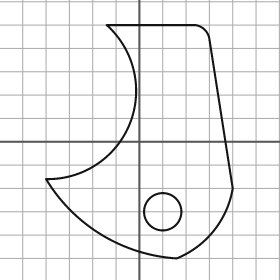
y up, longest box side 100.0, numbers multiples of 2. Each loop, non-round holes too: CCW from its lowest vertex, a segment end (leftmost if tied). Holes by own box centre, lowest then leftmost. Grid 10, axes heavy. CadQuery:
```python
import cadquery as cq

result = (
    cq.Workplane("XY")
    .moveTo(16.0, -50.0)
    .threePointArc((32.0, -38.0), (40.0, -20.0))
    .lineTo(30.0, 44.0)
    .threePointArc((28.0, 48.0), (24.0, 50.0))
    .lineTo(-14.0, 50.0)
    .threePointArc((-4.0, 8.0), (-40.0, -16.0))
    .threePointArc((-16.0, -40.0), (16.0, -50.0))
    .close()
    .moveTo(10.0, -30.0)
    .circle(8.0)
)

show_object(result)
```